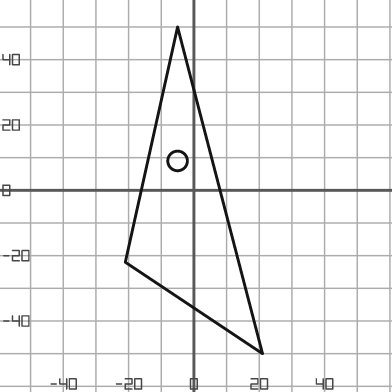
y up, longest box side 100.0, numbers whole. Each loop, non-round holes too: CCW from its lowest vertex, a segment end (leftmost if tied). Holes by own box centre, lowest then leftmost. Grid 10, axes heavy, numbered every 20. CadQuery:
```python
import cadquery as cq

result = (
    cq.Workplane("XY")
    .moveTo(21.0, -50.0)
    .lineTo(-5.0, 50.0)
    .lineTo(-21.0, -22.0)
    .close()
    .moveTo(-5.0, 9.0)
    .circle(3.0)
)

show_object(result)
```